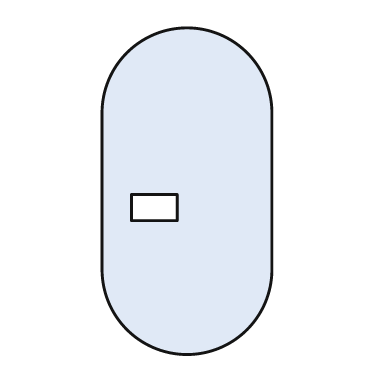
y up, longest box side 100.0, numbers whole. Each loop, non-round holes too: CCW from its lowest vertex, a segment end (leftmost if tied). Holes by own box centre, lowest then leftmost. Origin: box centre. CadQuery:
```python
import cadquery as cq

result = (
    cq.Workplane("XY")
    .moveTo(-26.0, -24.0)
    .threePointArc((0.0, -50.0), (26.0, -24.0))
    .lineTo(26.0, 24.0)
    .threePointArc((0.0, 50.0), (-26.0, 24.0))
    .close()
    .moveTo(-17.0, -9.0)
    .lineTo(-3.0, -9.0)
    .lineTo(-3.0, -1.0)
    .lineTo(-17.0, -1.0)
    .close()
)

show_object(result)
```